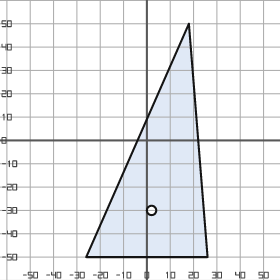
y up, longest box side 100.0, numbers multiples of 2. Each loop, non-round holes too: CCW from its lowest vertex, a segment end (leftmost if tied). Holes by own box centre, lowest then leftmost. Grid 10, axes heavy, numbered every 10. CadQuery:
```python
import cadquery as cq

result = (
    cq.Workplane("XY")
    .moveTo(-26.0, -50.0)
    .lineTo(26.0, -50.0)
    .lineTo(18.0, 50.0)
    .close()
    .moveTo(2.0, -30.0)
    .circle(2.0)
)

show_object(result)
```